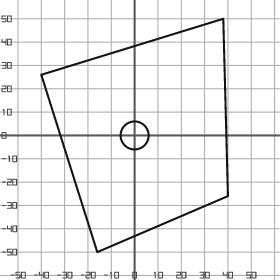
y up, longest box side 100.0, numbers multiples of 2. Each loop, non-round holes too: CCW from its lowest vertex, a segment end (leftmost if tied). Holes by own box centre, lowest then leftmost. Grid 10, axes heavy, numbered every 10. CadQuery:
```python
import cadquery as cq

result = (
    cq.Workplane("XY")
    .moveTo(-16.0, -50.0)
    .lineTo(40.0, -26.0)
    .lineTo(38.0, 50.0)
    .lineTo(-40.0, 26.0)
    .close()
    .moveTo(0.0, 0.0)
    .circle(6.0)
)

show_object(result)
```